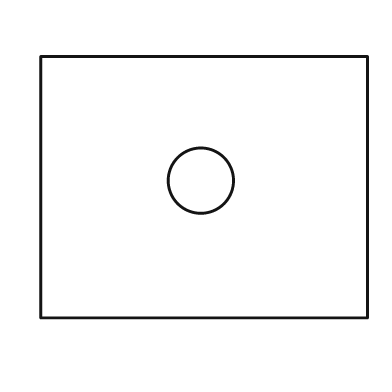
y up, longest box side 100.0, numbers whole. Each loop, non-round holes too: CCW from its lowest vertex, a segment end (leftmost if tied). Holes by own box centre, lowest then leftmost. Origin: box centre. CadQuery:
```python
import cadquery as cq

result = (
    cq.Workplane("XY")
    .moveTo(-50.0, -40.0)
    .lineTo(50.0, -40.0)
    .lineTo(50.0, 40.0)
    .lineTo(-50.0, 40.0)
    .close()
    .moveTo(-1.0, 2.0)
    .circle(10.0)
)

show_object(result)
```